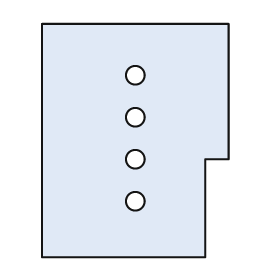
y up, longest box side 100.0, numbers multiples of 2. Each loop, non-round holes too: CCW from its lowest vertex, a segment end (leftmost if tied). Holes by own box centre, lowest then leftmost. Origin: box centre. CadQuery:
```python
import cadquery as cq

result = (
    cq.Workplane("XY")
    .moveTo(-40.0, -50.0)
    .lineTo(30.0, -50.0)
    .lineTo(30.0, -8.0)
    .lineTo(40.0, -8.0)
    .lineTo(40.0, 50.0)
    .lineTo(-40.0, 50.0)
    .close()
    .moveTo(0.0, -26.0)
    .circle(4.0)
    .moveTo(0.0, -8.0)
    .circle(4.0)
    .moveTo(0.0, 10.0)
    .circle(4.0)
    .moveTo(0.0, 28.0)
    .circle(4.0)
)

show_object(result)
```